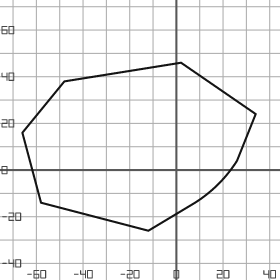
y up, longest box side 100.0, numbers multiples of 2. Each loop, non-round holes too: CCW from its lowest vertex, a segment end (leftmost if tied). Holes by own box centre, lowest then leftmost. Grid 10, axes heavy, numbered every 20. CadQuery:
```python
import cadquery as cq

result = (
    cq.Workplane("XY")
    .moveTo(-12.0, -26.0)
    .lineTo(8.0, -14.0)
    .threePointArc((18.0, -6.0), (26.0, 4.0))
    .lineTo(34.0, 24.0)
    .lineTo(2.0, 46.0)
    .lineTo(-48.0, 38.0)
    .lineTo(-66.0, 16.0)
    .lineTo(-58.0, -14.0)
    .close()
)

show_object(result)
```